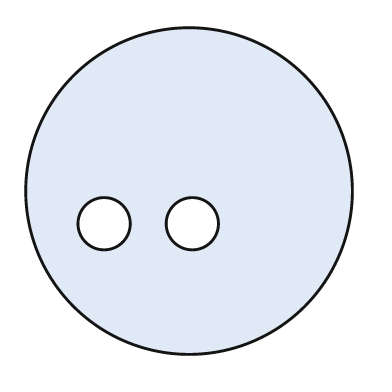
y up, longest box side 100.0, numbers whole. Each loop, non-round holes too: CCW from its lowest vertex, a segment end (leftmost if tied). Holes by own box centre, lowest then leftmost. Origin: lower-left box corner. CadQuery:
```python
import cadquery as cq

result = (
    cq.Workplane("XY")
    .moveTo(50.0, 50.0)
    .circle(50.0)
    .moveTo(24.0, 40.0)
    .circle(8.0)
    .moveTo(51.0, 40.0)
    .circle(8.0)
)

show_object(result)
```